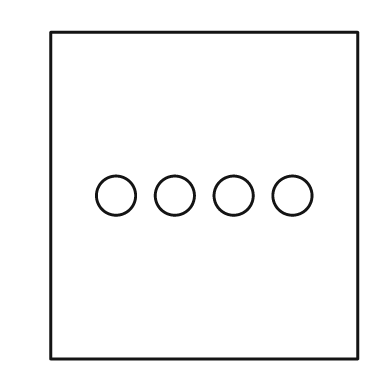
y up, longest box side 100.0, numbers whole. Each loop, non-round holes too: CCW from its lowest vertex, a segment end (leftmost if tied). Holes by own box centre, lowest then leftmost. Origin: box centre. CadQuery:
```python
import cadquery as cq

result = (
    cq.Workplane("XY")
    .moveTo(-47.0, -50.0)
    .lineTo(47.0, -50.0)
    .lineTo(47.0, 50.0)
    .lineTo(-47.0, 50.0)
    .close()
    .moveTo(-27.0, 0.0)
    .circle(6.0)
    .moveTo(-9.0, 0.0)
    .circle(6.0)
    .moveTo(9.0, 0.0)
    .circle(6.0)
    .moveTo(27.0, 0.0)
    .circle(6.0)
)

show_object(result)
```